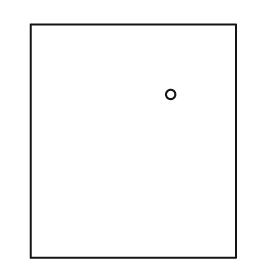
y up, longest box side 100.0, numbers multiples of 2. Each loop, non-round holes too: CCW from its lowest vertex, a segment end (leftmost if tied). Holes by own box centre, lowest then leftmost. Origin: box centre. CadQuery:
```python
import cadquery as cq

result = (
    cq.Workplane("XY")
    .moveTo(-44.0, -50.0)
    .lineTo(44.0, -50.0)
    .lineTo(44.0, 50.0)
    .lineTo(-44.0, 50.0)
    .close()
    .moveTo(16.0, 20.0)
    .circle(2.0)
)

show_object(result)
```